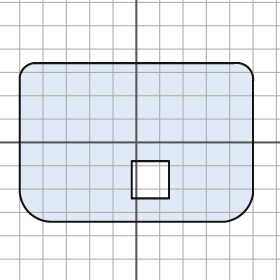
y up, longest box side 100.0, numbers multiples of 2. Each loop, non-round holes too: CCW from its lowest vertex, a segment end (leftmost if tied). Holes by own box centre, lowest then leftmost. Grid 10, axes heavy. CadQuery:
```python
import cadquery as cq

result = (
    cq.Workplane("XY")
    .moveTo(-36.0, -34.0)
    .lineTo(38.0, -34.0)
    .threePointArc((46.0, -30.0), (50.0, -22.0))
    .lineTo(50.0, 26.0)
    .threePointArc((48.0, 32.0), (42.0, 34.0))
    .lineTo(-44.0, 34.0)
    .threePointArc((-48.0, 32.0), (-50.0, 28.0))
    .lineTo(-50.0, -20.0)
    .threePointArc((-46.0, -30.0), (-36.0, -34.0))
    .close()
    .moveTo(-2.0, -24.0)
    .lineTo(14.0, -24.0)
    .lineTo(14.0, -8.0)
    .lineTo(-2.0, -8.0)
    .close()
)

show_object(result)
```